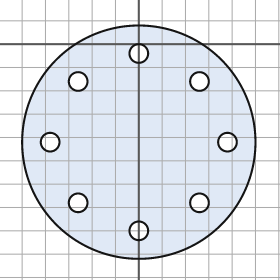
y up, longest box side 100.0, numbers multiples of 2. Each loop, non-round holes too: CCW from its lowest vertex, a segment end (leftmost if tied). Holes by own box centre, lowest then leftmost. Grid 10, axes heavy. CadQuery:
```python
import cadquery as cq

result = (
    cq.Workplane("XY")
    .moveTo(0.0, -42.0)
    .circle(50.0)
    .moveTo(0.0, -80.0)
    .circle(4.0)
    .moveTo(-26.0, -68.0)
    .circle(4.0)
    .moveTo(26.0, -68.0)
    .circle(4.0)
    .moveTo(-38.0, -42.0)
    .circle(4.0)
    .moveTo(38.0, -42.0)
    .circle(4.0)
    .moveTo(-26.0, -16.0)
    .circle(4.0)
    .moveTo(26.0, -16.0)
    .circle(4.0)
    .moveTo(0.0, -4.0)
    .circle(4.0)
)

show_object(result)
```